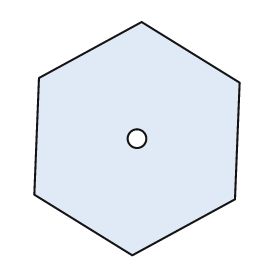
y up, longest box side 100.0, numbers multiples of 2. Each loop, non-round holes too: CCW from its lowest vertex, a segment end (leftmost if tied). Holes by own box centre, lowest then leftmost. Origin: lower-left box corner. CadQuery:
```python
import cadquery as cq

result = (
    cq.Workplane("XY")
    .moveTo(42.0, 0.0)
    .lineTo(86.0, 24.0)
    .lineTo(88.0, 74.0)
    .lineTo(46.0, 100.0)
    .lineTo(2.0, 76.0)
    .lineTo(0.0, 26.0)
    .close()
    .moveTo(44.0, 50.0)
    .circle(4.0)
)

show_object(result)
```